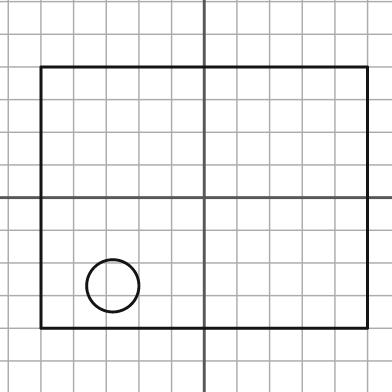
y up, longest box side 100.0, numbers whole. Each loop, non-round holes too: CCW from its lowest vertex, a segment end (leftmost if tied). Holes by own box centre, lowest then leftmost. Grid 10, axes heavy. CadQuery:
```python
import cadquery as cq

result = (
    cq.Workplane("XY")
    .moveTo(-50.0, -40.0)
    .lineTo(50.0, -40.0)
    .lineTo(50.0, 40.0)
    .lineTo(-50.0, 40.0)
    .close()
    .moveTo(-28.0, -27.0)
    .circle(8.0)
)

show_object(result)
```